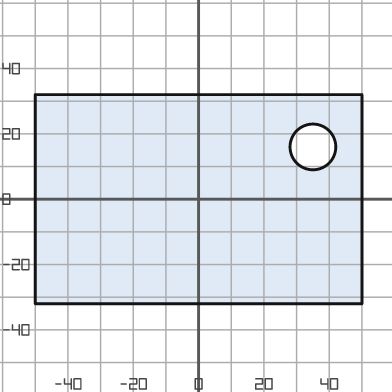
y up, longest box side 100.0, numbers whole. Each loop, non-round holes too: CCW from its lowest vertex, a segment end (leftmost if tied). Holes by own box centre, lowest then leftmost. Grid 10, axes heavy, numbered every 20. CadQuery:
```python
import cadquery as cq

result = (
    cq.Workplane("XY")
    .moveTo(-50.0, -32.0)
    .lineTo(50.0, -32.0)
    .lineTo(50.0, 32.0)
    .lineTo(-50.0, 32.0)
    .close()
    .moveTo(35.0, 16.0)
    .circle(7.0)
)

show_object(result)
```